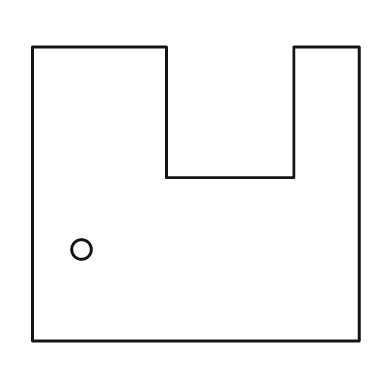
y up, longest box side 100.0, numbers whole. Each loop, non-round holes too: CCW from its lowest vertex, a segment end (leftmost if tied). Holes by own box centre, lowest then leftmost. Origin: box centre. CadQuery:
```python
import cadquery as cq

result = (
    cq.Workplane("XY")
    .moveTo(-50.0, -45.0)
    .lineTo(50.0, -45.0)
    .lineTo(50.0, 45.0)
    .lineTo(30.0, 45.0)
    .lineTo(30.0, 5.0)
    .lineTo(-9.0, 5.0)
    .lineTo(-9.0, 45.0)
    .lineTo(-50.0, 45.0)
    .close()
    .moveTo(-35.0, -17.0)
    .circle(3.0)
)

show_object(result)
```